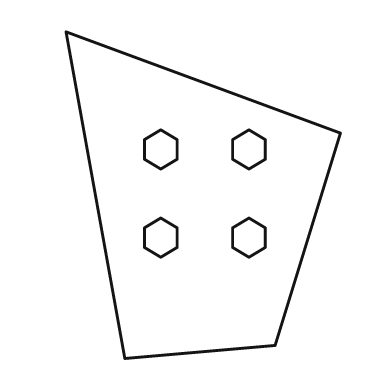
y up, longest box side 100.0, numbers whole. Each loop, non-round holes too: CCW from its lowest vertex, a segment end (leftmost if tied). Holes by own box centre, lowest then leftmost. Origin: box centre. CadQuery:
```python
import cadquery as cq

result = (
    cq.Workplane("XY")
    .moveTo(-24.0, -50.0)
    .lineTo(22.0, -46.0)
    .lineTo(42.0, 19.0)
    .lineTo(-42.0, 50.0)
    .close()
    .moveTo(-13.0, -19.0)
    .lineTo(-8.0, -16.0)
    .lineTo(-8.0, -10.0)
    .lineTo(-13.0, -7.0)
    .lineTo(-18.0, -10.0)
    .lineTo(-18.0, -16.0)
    .close()
    .moveTo(14.0, -19.0)
    .lineTo(19.0, -16.0)
    .lineTo(19.0, -10.0)
    .lineTo(14.0, -7.0)
    .lineTo(9.0, -10.0)
    .lineTo(9.0, -16.0)
    .close()
    .moveTo(-13.0, 8.0)
    .lineTo(-8.0, 11.0)
    .lineTo(-8.0, 17.0)
    .lineTo(-13.0, 20.0)
    .lineTo(-18.0, 17.0)
    .lineTo(-18.0, 11.0)
    .close()
    .moveTo(14.0, 8.0)
    .lineTo(19.0, 11.0)
    .lineTo(19.0, 17.0)
    .lineTo(14.0, 20.0)
    .lineTo(9.0, 17.0)
    .lineTo(9.0, 11.0)
    .close()
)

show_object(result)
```